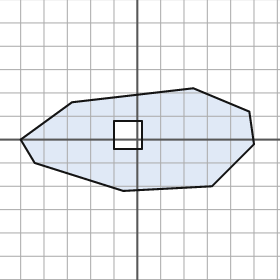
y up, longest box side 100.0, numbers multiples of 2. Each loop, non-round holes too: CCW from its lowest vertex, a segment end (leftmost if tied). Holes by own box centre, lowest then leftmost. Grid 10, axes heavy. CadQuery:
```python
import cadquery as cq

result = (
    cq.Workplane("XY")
    .moveTo(-6.0, -22.0)
    .lineTo(32.0, -20.0)
    .lineTo(50.0, -2.0)
    .lineTo(48.0, 12.0)
    .lineTo(24.0, 22.0)
    .lineTo(-28.0, 16.0)
    .lineTo(-50.0, 0.0)
    .lineTo(-44.0, -10.0)
    .close()
    .moveTo(-10.0, -4.0)
    .lineTo(2.0, -4.0)
    .lineTo(2.0, 8.0)
    .lineTo(-10.0, 8.0)
    .close()
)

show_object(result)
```